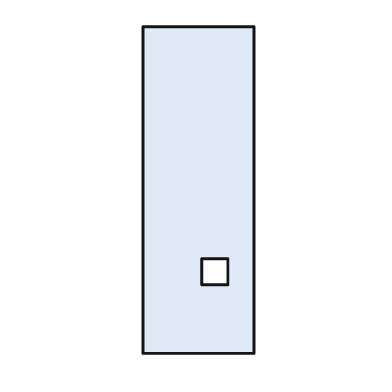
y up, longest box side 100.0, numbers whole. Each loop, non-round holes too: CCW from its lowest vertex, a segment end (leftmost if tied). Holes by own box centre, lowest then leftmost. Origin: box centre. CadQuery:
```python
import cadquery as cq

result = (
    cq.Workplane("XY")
    .moveTo(-17.0, -50.0)
    .lineTo(17.0, -50.0)
    .lineTo(17.0, 50.0)
    .lineTo(-17.0, 50.0)
    .close()
    .moveTo(1.0, -29.0)
    .lineTo(9.0, -29.0)
    .lineTo(9.0, -21.0)
    .lineTo(1.0, -21.0)
    .close()
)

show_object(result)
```